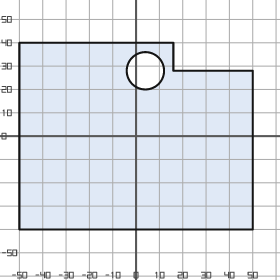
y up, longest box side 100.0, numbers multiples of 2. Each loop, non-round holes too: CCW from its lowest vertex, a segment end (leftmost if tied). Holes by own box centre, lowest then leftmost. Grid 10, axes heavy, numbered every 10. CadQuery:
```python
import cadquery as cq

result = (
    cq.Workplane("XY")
    .moveTo(-50.0, -40.0)
    .lineTo(50.0, -40.0)
    .lineTo(50.0, 28.0)
    .lineTo(16.0, 28.0)
    .lineTo(16.0, 40.0)
    .lineTo(-50.0, 40.0)
    .close()
    .moveTo(4.0, 28.0)
    .circle(8.0)
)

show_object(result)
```